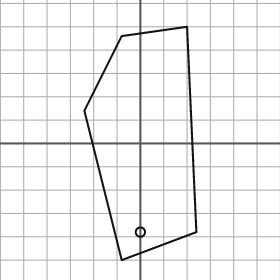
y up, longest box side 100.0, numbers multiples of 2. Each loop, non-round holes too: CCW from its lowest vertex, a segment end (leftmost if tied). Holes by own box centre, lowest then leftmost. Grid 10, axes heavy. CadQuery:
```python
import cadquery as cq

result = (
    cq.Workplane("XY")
    .moveTo(-8.0, -50.0)
    .lineTo(24.0, -38.0)
    .lineTo(20.0, 50.0)
    .lineTo(-8.0, 46.0)
    .lineTo(-24.0, 14.0)
    .close()
    .moveTo(0.0, -38.0)
    .circle(2.0)
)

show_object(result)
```